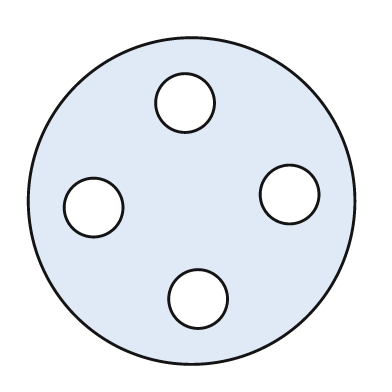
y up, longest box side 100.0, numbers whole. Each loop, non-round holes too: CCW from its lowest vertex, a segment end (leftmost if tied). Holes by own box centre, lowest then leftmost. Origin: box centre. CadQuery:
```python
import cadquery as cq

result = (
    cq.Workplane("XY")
    .moveTo(0.0, 0.0)
    .circle(50.0)
    .moveTo(2.0, -30.0)
    .circle(9.0)
    .moveTo(-30.0, -2.0)
    .circle(9.0)
    .moveTo(30.0, 2.0)
    .circle(9.0)
    .moveTo(-2.0, 30.0)
    .circle(9.0)
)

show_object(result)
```